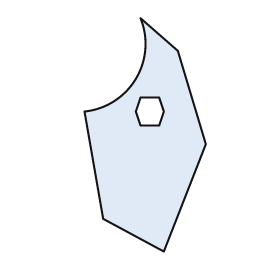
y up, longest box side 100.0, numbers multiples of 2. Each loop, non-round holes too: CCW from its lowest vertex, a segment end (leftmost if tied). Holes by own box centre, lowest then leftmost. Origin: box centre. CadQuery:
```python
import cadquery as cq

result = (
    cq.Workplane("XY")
    .moveTo(8.0, -50.0)
    .lineTo(26.0, -4.0)
    .lineTo(14.0, 36.0)
    .lineTo(-2.0, 50.0)
    .threePointArc((-4.0, 24.0), (-26.0, 10.0))
    .lineTo(-18.0, -36.0)
    .close()
    .moveTo(-2.0, 4.0)
    .lineTo(6.0, 4.0)
    .lineTo(8.0, 10.0)
    .lineTo(6.0, 16.0)
    .lineTo(-2.0, 16.0)
    .lineTo(-4.0, 10.0)
    .close()
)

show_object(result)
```